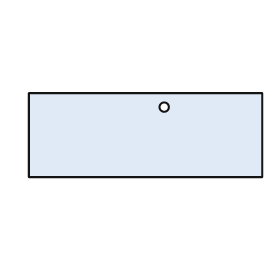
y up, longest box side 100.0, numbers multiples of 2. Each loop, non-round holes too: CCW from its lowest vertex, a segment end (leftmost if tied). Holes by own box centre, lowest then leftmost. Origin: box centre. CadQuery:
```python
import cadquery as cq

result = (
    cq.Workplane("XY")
    .moveTo(-50.0, -18.0)
    .lineTo(50.0, -18.0)
    .lineTo(50.0, 18.0)
    .lineTo(-50.0, 18.0)
    .close()
    .moveTo(8.0, 12.0)
    .circle(2.0)
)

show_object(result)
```